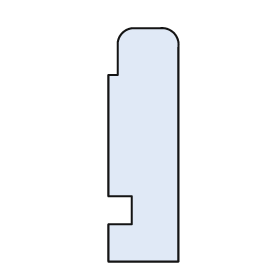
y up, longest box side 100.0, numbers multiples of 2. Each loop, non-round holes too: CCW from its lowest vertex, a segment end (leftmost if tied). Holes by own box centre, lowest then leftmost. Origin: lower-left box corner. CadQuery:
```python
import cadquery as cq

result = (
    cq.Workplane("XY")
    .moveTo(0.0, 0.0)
    .lineTo(30.0, 0.0)
    .lineTo(30.0, 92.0)
    .threePointArc((28.0, 98.0), (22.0, 100.0))
    .lineTo(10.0, 100.0)
    .threePointArc((6.0, 98.0), (4.0, 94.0))
    .lineTo(4.0, 80.0)
    .lineTo(0.0, 80.0)
    .lineTo(0.0, 28.0)
    .lineTo(10.0, 28.0)
    .lineTo(10.0, 16.0)
    .lineTo(0.0, 16.0)
    .close()
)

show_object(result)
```